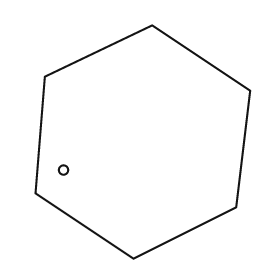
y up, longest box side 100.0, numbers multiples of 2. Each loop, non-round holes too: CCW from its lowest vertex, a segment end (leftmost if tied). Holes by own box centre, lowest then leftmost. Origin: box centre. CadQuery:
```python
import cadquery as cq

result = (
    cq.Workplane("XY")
    .moveTo(-4.0, -50.0)
    .lineTo(40.0, -28.0)
    .lineTo(46.0, 22.0)
    .lineTo(4.0, 50.0)
    .lineTo(-42.0, 28.0)
    .lineTo(-46.0, -22.0)
    .close()
    .moveTo(-34.0, -12.0)
    .circle(2.0)
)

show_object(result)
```